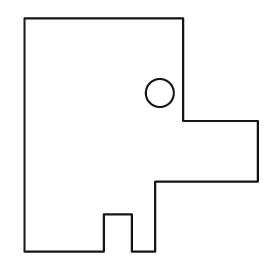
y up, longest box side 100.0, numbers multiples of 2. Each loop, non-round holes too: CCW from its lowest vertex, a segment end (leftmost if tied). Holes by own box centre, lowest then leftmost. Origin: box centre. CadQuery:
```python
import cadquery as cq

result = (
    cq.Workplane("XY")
    .moveTo(-50.0, -50.0)
    .lineTo(-16.0, -50.0)
    .lineTo(-16.0, -34.0)
    .lineTo(-4.0, -34.0)
    .lineTo(-4.0, -50.0)
    .lineTo(6.0, -50.0)
    .lineTo(6.0, -20.0)
    .lineTo(50.0, -20.0)
    .lineTo(50.0, 6.0)
    .lineTo(18.0, 6.0)
    .lineTo(18.0, 50.0)
    .lineTo(-50.0, 50.0)
    .close()
    .moveTo(8.0, 18.0)
    .circle(6.0)
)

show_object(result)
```